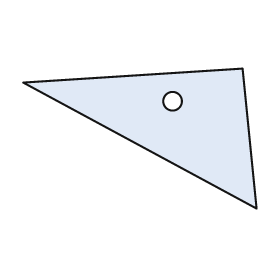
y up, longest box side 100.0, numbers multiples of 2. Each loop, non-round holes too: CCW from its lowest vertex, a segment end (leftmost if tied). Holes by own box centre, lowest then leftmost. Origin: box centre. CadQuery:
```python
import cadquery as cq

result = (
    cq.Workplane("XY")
    .moveTo(50.0, -30.0)
    .lineTo(44.0, 30.0)
    .lineTo(-50.0, 24.0)
    .close()
    .moveTo(14.0, 16.0)
    .circle(4.0)
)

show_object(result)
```